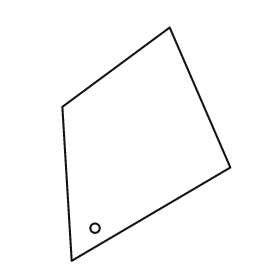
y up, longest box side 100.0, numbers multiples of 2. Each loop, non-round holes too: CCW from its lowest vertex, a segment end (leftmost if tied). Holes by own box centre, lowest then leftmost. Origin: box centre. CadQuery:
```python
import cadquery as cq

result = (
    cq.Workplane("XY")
    .moveTo(-32.0, -50.0)
    .lineTo(36.0, -10.0)
    .lineTo(10.0, 50.0)
    .lineTo(-36.0, 16.0)
    .close()
    .moveTo(-22.0, -36.0)
    .circle(2.0)
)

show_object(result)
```